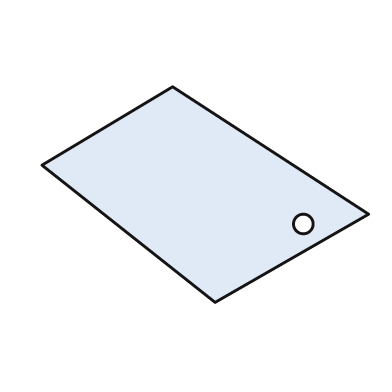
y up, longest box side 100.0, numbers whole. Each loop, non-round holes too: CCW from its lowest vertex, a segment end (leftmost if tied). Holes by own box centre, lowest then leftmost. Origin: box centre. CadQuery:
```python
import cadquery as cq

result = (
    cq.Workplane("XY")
    .moveTo(3.0, -33.0)
    .lineTo(50.0, -6.0)
    .lineTo(-10.0, 33.0)
    .lineTo(-50.0, 9.0)
    .close()
    .moveTo(30.0, -9.0)
    .circle(3.0)
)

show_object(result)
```